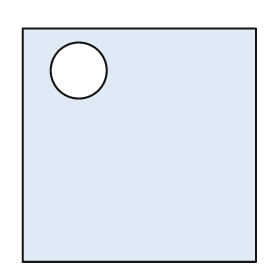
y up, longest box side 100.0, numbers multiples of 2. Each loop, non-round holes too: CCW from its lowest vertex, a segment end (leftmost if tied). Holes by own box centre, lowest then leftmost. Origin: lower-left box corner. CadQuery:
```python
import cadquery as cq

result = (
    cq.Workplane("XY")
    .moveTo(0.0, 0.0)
    .lineTo(100.0, 0.0)
    .lineTo(100.0, 100.0)
    .lineTo(0.0, 100.0)
    .close()
    .moveTo(24.0, 82.0)
    .circle(12.0)
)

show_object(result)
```